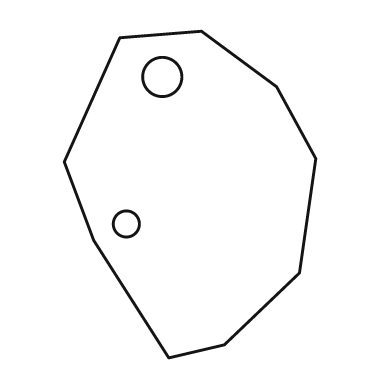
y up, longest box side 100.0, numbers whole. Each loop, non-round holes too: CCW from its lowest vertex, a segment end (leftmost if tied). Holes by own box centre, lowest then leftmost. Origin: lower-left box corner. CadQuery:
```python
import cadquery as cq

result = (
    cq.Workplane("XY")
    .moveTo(32.0, 0.0)
    .lineTo(49.0, 4.0)
    .lineTo(72.0, 26.0)
    .lineTo(77.0, 61.0)
    .lineTo(65.0, 83.0)
    .lineTo(42.0, 100.0)
    .lineTo(17.0, 98.0)
    .lineTo(0.0, 60.0)
    .lineTo(9.0, 36.0)
    .close()
    .moveTo(19.0, 41.0)
    .circle(4.0)
    .moveTo(30.0, 86.0)
    .circle(6.0)
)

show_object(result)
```